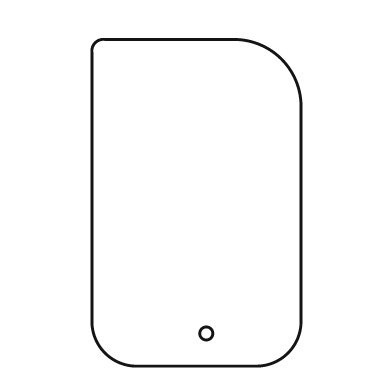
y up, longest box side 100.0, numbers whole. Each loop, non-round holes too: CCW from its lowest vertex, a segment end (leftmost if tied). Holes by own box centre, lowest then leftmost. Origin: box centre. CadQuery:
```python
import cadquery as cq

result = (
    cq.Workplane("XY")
    .moveTo(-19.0, -50.0)
    .lineTo(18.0, -50.0)
    .threePointArc((28.0, -46.0), (32.0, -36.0))
    .lineTo(32.0, 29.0)
    .threePointArc((26.0, 44.0), (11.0, 50.0))
    .lineTo(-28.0, 50.0)
    .threePointArc((-31.0, 49.0), (-32.0, 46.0))
    .lineTo(-32.0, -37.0)
    .threePointArc((-28.0, -46.0), (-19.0, -50.0))
    .close()
    .moveTo(3.0, -40.0)
    .circle(2.0)
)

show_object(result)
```